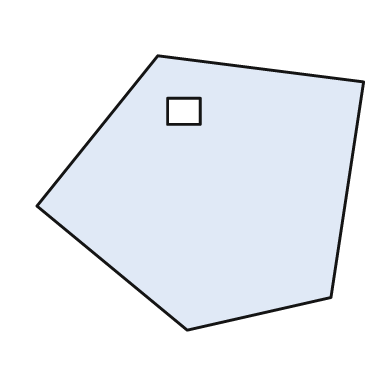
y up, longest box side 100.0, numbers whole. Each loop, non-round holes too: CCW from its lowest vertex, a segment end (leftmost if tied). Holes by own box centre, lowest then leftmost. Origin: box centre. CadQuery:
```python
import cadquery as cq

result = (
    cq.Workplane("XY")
    .moveTo(-4.0, -42.0)
    .lineTo(40.0, -32.0)
    .lineTo(50.0, 34.0)
    .lineTo(-13.0, 42.0)
    .lineTo(-50.0, -4.0)
    .close()
    .moveTo(-10.0, 21.0)
    .lineTo(0.0, 21.0)
    .lineTo(0.0, 29.0)
    .lineTo(-10.0, 29.0)
    .close()
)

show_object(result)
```